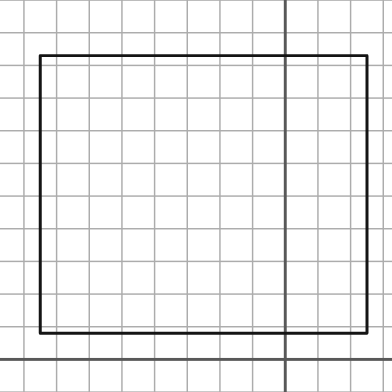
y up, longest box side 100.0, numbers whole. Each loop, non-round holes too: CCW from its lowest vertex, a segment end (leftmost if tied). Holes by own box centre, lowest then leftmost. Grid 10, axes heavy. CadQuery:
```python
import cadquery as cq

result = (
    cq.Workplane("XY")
    .moveTo(-75.0, 8.0)
    .lineTo(25.0, 8.0)
    .lineTo(25.0, 93.0)
    .lineTo(-75.0, 93.0)
    .close()
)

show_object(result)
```